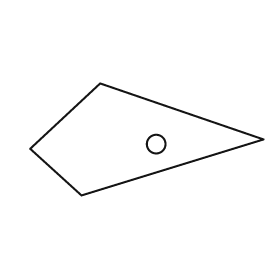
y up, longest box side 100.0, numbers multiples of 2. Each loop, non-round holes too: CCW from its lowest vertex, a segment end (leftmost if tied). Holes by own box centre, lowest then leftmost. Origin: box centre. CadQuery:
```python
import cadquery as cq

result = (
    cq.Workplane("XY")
    .moveTo(-28.0, -24.0)
    .lineTo(50.0, 0.0)
    .lineTo(-20.0, 24.0)
    .lineTo(-50.0, -4.0)
    .close()
    .moveTo(4.0, -2.0)
    .circle(4.0)
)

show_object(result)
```